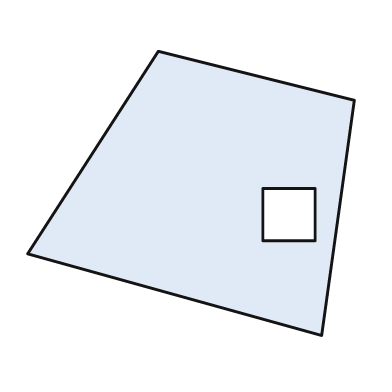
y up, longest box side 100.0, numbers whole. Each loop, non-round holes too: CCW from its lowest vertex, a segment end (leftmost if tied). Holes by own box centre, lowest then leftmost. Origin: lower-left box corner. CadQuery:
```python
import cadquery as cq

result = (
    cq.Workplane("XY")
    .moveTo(90.0, 0.0)
    .lineTo(100.0, 72.0)
    .lineTo(40.0, 87.0)
    .lineTo(0.0, 25.0)
    .close()
    .moveTo(72.0, 29.0)
    .lineTo(88.0, 29.0)
    .lineTo(88.0, 45.0)
    .lineTo(72.0, 45.0)
    .close()
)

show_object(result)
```